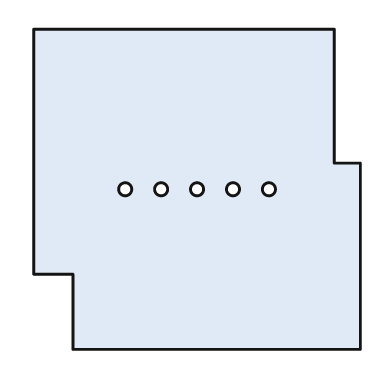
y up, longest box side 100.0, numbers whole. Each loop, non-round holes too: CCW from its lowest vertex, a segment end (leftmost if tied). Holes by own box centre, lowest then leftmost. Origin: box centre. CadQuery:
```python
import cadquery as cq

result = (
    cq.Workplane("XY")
    .moveTo(-38.0, -49.0)
    .lineTo(50.0, -49.0)
    .lineTo(50.0, 8.0)
    .lineTo(42.0, 8.0)
    .lineTo(42.0, 49.0)
    .lineTo(-50.0, 49.0)
    .lineTo(-50.0, -26.0)
    .lineTo(-38.0, -26.0)
    .close()
    .moveTo(-22.0, 0.0)
    .circle(2.0)
    .moveTo(-11.0, 0.0)
    .circle(2.0)
    .moveTo(0.0, 0.0)
    .circle(2.0)
    .moveTo(11.0, 0.0)
    .circle(2.0)
    .moveTo(22.0, 0.0)
    .circle(2.0)
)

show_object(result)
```